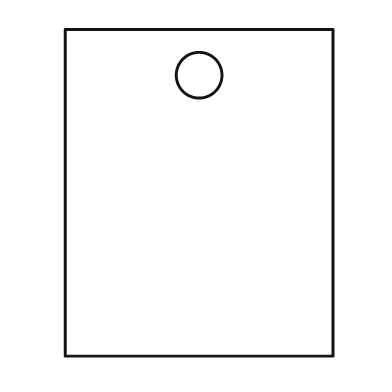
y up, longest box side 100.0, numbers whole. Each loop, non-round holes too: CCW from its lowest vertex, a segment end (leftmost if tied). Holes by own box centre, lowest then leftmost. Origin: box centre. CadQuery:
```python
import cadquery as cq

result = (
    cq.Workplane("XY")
    .moveTo(-41.0, -50.0)
    .lineTo(41.0, -50.0)
    .lineTo(41.0, 50.0)
    .lineTo(-41.0, 50.0)
    .close()
    .moveTo(0.0, 36.0)
    .circle(7.0)
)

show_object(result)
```